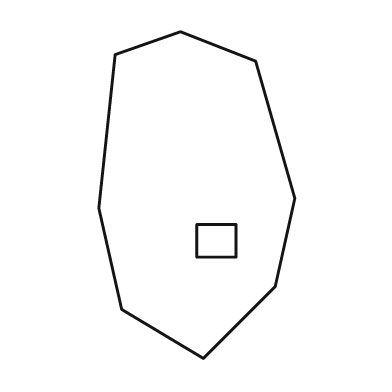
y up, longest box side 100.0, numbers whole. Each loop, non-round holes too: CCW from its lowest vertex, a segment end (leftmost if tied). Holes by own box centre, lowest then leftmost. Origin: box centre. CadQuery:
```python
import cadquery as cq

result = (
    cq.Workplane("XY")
    .moveTo(2.0, -50.0)
    .lineTo(24.0, -28.0)
    .lineTo(30.0, -1.0)
    .lineTo(18.0, 41.0)
    .lineTo(-5.0, 50.0)
    .lineTo(-25.0, 43.0)
    .lineTo(-30.0, -4.0)
    .lineTo(-23.0, -35.0)
    .close()
    .moveTo(0.0, -19.0)
    .lineTo(12.0, -19.0)
    .lineTo(12.0, -9.0)
    .lineTo(0.0, -9.0)
    .close()
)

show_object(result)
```